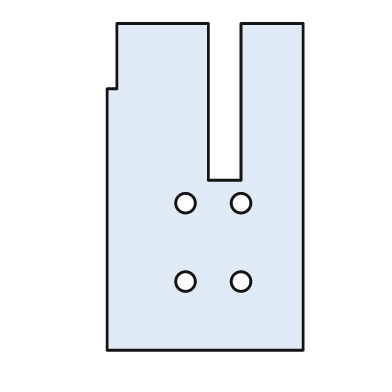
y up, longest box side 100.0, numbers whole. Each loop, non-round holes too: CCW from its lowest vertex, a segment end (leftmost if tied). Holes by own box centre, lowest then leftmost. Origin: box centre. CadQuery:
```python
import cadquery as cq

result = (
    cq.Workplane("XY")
    .moveTo(-30.0, -50.0)
    .lineTo(30.0, -50.0)
    .lineTo(30.0, 50.0)
    .lineTo(11.0, 50.0)
    .lineTo(11.0, 2.0)
    .lineTo(1.0, 2.0)
    .lineTo(1.0, 50.0)
    .lineTo(-27.0, 50.0)
    .lineTo(-27.0, 30.0)
    .lineTo(-30.0, 30.0)
    .close()
    .moveTo(-6.0, -29.0)
    .circle(3.0)
    .moveTo(11.0, -29.0)
    .circle(3.0)
    .moveTo(-6.0, -5.0)
    .circle(3.0)
    .moveTo(11.0, -5.0)
    .circle(3.0)
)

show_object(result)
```